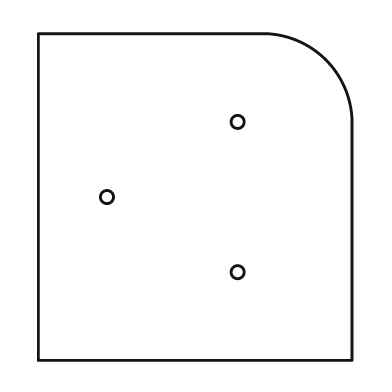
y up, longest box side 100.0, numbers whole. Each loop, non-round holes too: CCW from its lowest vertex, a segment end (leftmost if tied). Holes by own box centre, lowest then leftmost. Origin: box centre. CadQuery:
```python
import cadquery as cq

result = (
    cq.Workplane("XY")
    .moveTo(-48.0, -50.0)
    .lineTo(48.0, -50.0)
    .lineTo(48.0, 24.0)
    .threePointArc((40.0, 42.0), (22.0, 50.0))
    .lineTo(-48.0, 50.0)
    .close()
    .moveTo(13.0, -23.0)
    .circle(2.0)
    .moveTo(-27.0, 0.0)
    .circle(2.0)
    .moveTo(13.0, 23.0)
    .circle(2.0)
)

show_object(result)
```